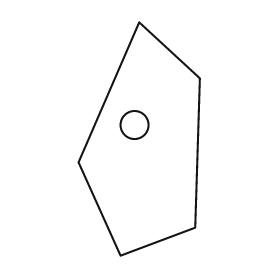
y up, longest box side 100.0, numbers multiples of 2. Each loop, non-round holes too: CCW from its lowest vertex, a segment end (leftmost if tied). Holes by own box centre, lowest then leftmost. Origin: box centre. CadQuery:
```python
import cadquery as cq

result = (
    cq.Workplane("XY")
    .moveTo(-8.0, -50.0)
    .lineTo(24.0, -38.0)
    .lineTo(26.0, 26.0)
    .lineTo(0.0, 50.0)
    .lineTo(-26.0, -10.0)
    .close()
    .moveTo(-2.0, 6.0)
    .circle(6.0)
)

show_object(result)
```